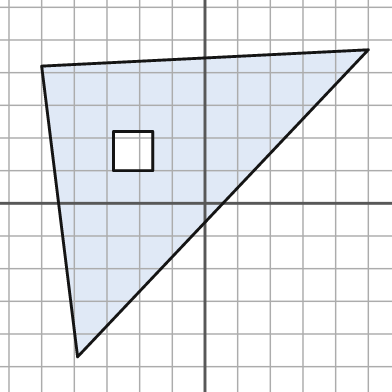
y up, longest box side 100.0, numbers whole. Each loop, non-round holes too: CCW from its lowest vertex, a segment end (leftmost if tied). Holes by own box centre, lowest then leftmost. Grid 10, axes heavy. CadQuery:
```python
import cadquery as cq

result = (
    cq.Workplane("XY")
    .moveTo(-39.0, -47.0)
    .lineTo(50.0, 47.0)
    .lineTo(-50.0, 42.0)
    .close()
    .moveTo(-28.0, 10.0)
    .lineTo(-16.0, 10.0)
    .lineTo(-16.0, 22.0)
    .lineTo(-28.0, 22.0)
    .close()
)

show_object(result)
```